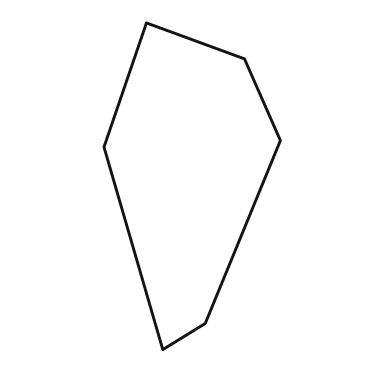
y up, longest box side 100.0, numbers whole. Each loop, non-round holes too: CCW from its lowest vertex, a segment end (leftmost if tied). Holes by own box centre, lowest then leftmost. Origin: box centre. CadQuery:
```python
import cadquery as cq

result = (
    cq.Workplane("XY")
    .moveTo(-9.0, -50.0)
    .lineTo(4.0, -42.0)
    .lineTo(27.0, 14.0)
    .lineTo(16.0, 39.0)
    .lineTo(-14.0, 50.0)
    .lineTo(-27.0, 12.0)
    .close()
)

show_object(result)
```